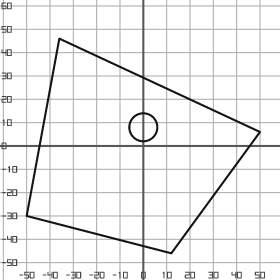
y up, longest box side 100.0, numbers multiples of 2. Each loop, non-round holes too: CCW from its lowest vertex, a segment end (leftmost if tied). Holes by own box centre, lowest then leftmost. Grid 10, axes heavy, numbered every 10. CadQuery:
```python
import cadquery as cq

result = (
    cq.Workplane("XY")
    .moveTo(12.0, -46.0)
    .lineTo(50.0, 6.0)
    .lineTo(-36.0, 46.0)
    .lineTo(-50.0, -30.0)
    .close()
    .moveTo(0.0, 8.0)
    .circle(6.0)
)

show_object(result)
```